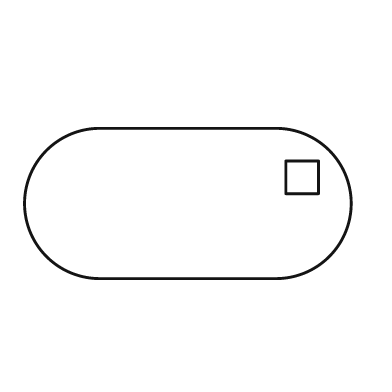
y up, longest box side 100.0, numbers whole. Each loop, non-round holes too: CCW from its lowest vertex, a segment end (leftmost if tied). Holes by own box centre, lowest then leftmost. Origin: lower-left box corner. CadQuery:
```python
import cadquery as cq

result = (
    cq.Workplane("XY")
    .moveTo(23.0, 0.0)
    .lineTo(77.0, 0.0)
    .threePointArc((100.0, 23.0), (77.0, 46.0))
    .lineTo(23.0, 46.0)
    .threePointArc((0.0, 23.0), (23.0, 0.0))
    .close()
    .moveTo(80.0, 26.0)
    .lineTo(90.0, 26.0)
    .lineTo(90.0, 36.0)
    .lineTo(80.0, 36.0)
    .close()
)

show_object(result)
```